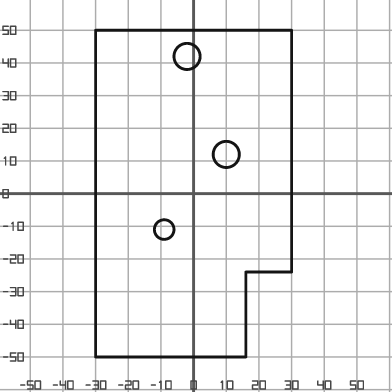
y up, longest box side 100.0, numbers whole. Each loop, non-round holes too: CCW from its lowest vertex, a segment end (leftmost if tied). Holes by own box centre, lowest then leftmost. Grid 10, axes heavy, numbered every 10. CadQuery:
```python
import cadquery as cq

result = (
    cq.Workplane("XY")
    .moveTo(-30.0, -50.0)
    .lineTo(16.0, -50.0)
    .lineTo(16.0, -24.0)
    .lineTo(30.0, -24.0)
    .lineTo(30.0, 50.0)
    .lineTo(-30.0, 50.0)
    .close()
    .moveTo(-9.0, -11.0)
    .circle(3.0)
    .moveTo(10.0, 12.0)
    .circle(4.0)
    .moveTo(-2.0, 42.0)
    .circle(4.0)
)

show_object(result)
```